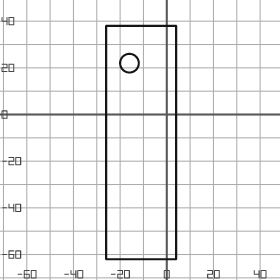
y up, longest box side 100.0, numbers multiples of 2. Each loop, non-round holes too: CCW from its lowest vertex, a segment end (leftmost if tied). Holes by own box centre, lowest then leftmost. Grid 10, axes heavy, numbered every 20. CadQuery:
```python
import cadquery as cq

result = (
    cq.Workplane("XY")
    .moveTo(-26.0, -62.0)
    .lineTo(4.0, -62.0)
    .lineTo(4.0, 38.0)
    .lineTo(-26.0, 38.0)
    .close()
    .moveTo(-16.0, 22.0)
    .circle(4.0)
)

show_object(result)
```